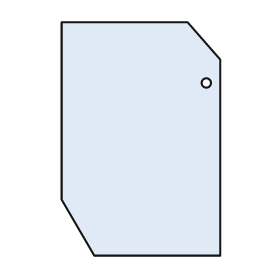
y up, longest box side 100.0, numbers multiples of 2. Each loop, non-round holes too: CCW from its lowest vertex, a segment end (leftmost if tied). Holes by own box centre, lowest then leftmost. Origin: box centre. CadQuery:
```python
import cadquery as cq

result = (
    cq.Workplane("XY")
    .moveTo(-20.0, -50.0)
    .lineTo(34.0, -50.0)
    .lineTo(34.0, 34.0)
    .lineTo(20.0, 50.0)
    .lineTo(-34.0, 50.0)
    .lineTo(-34.0, -26.0)
    .close()
    .moveTo(28.0, 24.0)
    .circle(2.0)
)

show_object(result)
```